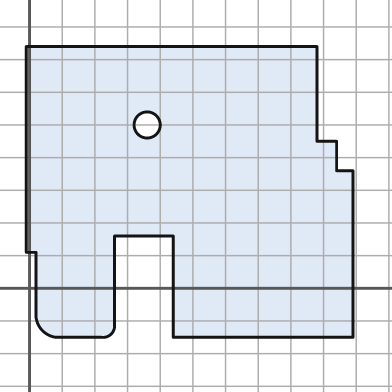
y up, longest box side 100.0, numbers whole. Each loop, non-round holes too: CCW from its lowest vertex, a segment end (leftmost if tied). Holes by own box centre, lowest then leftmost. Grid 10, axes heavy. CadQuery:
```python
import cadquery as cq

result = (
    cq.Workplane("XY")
    .moveTo(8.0, -15.0)
    .lineTo(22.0, -15.0)
    .threePointArc((25.0, -14.0), (26.0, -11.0))
    .lineTo(26.0, 16.0)
    .lineTo(44.0, 16.0)
    .lineTo(44.0, -15.0)
    .lineTo(99.0, -15.0)
    .lineTo(99.0, 36.0)
    .lineTo(94.0, 36.0)
    .lineTo(94.0, 45.0)
    .lineTo(88.0, 45.0)
    .lineTo(88.0, 74.0)
    .lineTo(-1.0, 74.0)
    .lineTo(-1.0, 11.0)
    .lineTo(2.0, 11.0)
    .lineTo(2.0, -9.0)
    .threePointArc((4.0, -13.0), (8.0, -15.0))
    .close()
    .moveTo(36.0, 50.0)
    .circle(4.0)
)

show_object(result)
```